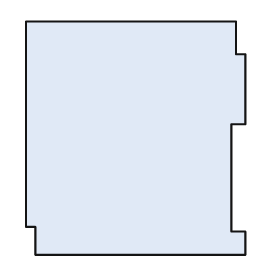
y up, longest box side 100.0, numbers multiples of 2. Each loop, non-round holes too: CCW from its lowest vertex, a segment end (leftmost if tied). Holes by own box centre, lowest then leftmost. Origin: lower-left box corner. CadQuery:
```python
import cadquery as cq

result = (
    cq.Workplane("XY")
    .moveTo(4.0, 0.0)
    .lineTo(94.0, 0.0)
    .lineTo(94.0, 10.0)
    .lineTo(88.0, 10.0)
    .lineTo(88.0, 56.0)
    .lineTo(94.0, 56.0)
    .lineTo(94.0, 86.0)
    .lineTo(90.0, 86.0)
    .lineTo(90.0, 100.0)
    .lineTo(0.0, 100.0)
    .lineTo(0.0, 12.0)
    .lineTo(4.0, 12.0)
    .close()
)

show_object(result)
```